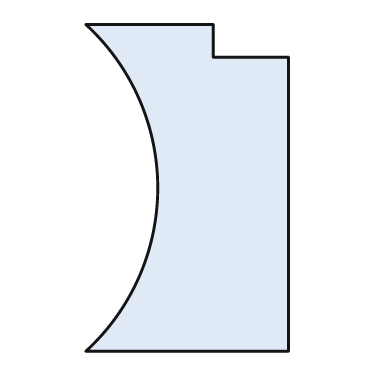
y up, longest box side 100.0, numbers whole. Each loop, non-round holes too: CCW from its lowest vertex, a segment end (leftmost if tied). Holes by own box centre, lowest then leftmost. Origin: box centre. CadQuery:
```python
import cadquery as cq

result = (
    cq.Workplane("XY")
    .moveTo(-31.0, -50.0)
    .lineTo(31.0, -50.0)
    .lineTo(31.0, 40.0)
    .lineTo(8.0, 40.0)
    .lineTo(8.0, 50.0)
    .lineTo(-31.0, 50.0)
    .threePointArc((-9.0, 0.0), (-31.0, -50.0))
    .close()
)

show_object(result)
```